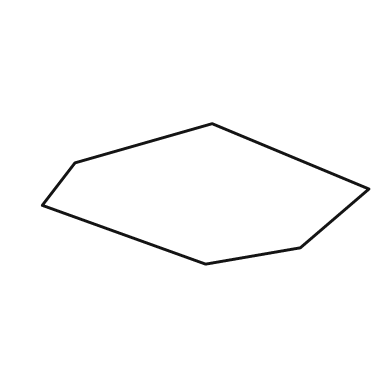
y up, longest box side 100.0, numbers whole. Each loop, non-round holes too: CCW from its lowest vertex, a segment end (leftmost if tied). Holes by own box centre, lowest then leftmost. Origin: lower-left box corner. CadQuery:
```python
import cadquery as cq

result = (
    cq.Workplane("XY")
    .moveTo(50.0, 0.0)
    .lineTo(79.0, 5.0)
    .lineTo(100.0, 23.0)
    .lineTo(52.0, 43.0)
    .lineTo(10.0, 31.0)
    .lineTo(0.0, 18.0)
    .close()
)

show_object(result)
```